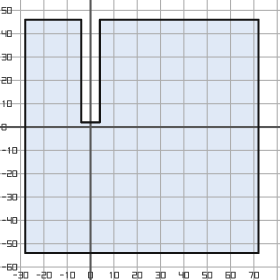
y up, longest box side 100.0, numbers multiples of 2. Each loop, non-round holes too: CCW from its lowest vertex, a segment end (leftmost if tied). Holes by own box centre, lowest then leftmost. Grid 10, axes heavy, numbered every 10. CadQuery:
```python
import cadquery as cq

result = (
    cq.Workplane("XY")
    .moveTo(-28.0, -54.0)
    .lineTo(72.0, -54.0)
    .lineTo(72.0, 46.0)
    .lineTo(4.0, 46.0)
    .lineTo(4.0, 2.0)
    .lineTo(-4.0, 2.0)
    .lineTo(-4.0, 46.0)
    .lineTo(-28.0, 46.0)
    .close()
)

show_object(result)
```